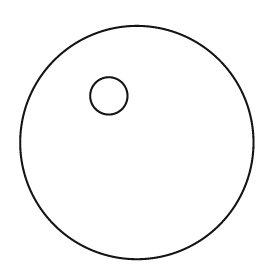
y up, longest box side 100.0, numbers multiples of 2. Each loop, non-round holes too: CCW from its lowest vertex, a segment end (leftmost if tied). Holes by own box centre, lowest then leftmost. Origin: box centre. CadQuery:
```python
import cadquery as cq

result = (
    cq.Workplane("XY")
    .moveTo(0.0, 0.0)
    .circle(50.0)
    .moveTo(-12.0, 20.0)
    .circle(8.0)
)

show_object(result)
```